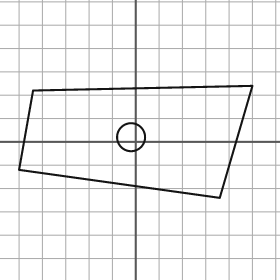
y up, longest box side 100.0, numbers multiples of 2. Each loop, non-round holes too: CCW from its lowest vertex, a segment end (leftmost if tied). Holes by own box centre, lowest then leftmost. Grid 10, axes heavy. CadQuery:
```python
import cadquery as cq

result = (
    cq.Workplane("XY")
    .moveTo(36.0, -24.0)
    .lineTo(50.0, 24.0)
    .lineTo(-44.0, 22.0)
    .lineTo(-50.0, -12.0)
    .close()
    .moveTo(-2.0, 2.0)
    .circle(6.0)
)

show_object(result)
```